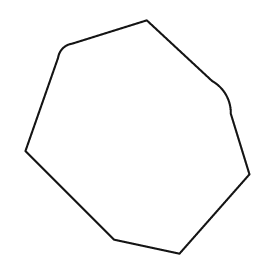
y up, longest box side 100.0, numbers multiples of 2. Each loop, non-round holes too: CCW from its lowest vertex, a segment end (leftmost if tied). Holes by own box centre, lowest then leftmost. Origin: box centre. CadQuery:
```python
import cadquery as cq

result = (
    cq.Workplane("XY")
    .moveTo(18.0, -50.0)
    .lineTo(48.0, -16.0)
    .lineTo(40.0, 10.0)
    .threePointArc((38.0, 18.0), (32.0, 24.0))
    .lineTo(4.0, 50.0)
    .lineTo(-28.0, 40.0)
    .threePointArc((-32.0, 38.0), (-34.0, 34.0))
    .lineTo(-48.0, -6.0)
    .lineTo(-10.0, -44.0)
    .close()
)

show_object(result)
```